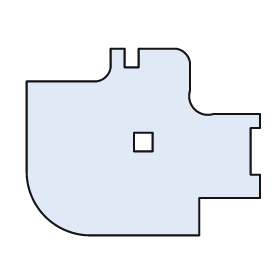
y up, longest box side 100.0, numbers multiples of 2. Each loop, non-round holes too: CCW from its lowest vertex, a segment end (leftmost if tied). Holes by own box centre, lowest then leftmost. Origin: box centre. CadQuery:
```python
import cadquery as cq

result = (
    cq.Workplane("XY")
    .moveTo(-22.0, -40.0)
    .lineTo(24.0, -40.0)
    .lineTo(24.0, -24.0)
    .lineTo(50.0, -24.0)
    .lineTo(50.0, -14.0)
    .lineTo(46.0, -14.0)
    .lineTo(46.0, 6.0)
    .lineTo(50.0, 6.0)
    .lineTo(50.0, 12.0)
    .lineTo(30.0, 12.0)
    .threePointArc((22.0, 14.0), (20.0, 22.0))
    .lineTo(20.0, 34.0)
    .threePointArc((18.0, 38.0), (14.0, 40.0))
    .lineTo(-2.0, 40.0)
    .lineTo(-2.0, 32.0)
    .lineTo(-8.0, 32.0)
    .lineTo(-8.0, 40.0)
    .lineTo(-14.0, 40.0)
    .lineTo(-14.0, 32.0)
    .threePointArc((-16.0, 28.0), (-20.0, 26.0))
    .lineTo(-50.0, 26.0)
    .lineTo(-50.0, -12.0)
    .threePointArc((-42.0, -32.0), (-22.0, -40.0))
    .close()
    .moveTo(-4.0, -4.0)
    .lineTo(4.0, -4.0)
    .lineTo(4.0, 4.0)
    .lineTo(-4.0, 4.0)
    .close()
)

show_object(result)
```